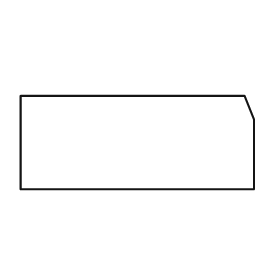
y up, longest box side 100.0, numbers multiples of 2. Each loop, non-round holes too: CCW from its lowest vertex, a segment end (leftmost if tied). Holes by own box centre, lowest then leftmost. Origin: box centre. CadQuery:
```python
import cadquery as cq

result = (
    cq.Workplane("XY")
    .moveTo(-50.0, -20.0)
    .lineTo(50.0, -20.0)
    .lineTo(50.0, 10.0)
    .lineTo(46.0, 20.0)
    .lineTo(-50.0, 20.0)
    .close()
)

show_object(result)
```